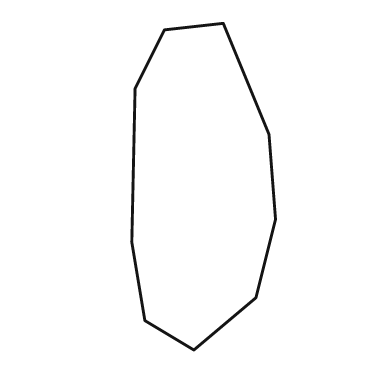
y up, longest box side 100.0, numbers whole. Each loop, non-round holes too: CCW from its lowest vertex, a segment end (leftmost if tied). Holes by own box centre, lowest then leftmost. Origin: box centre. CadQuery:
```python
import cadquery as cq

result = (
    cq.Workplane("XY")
    .moveTo(-3.0, -50.0)
    .lineTo(16.0, -34.0)
    .lineTo(22.0, -10.0)
    .lineTo(20.0, 16.0)
    .lineTo(6.0, 50.0)
    .lineTo(-12.0, 48.0)
    .lineTo(-21.0, 30.0)
    .lineTo(-22.0, -17.0)
    .lineTo(-18.0, -41.0)
    .close()
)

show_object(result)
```